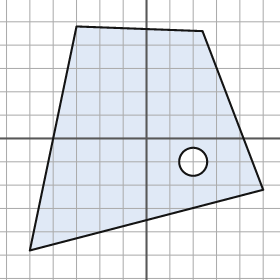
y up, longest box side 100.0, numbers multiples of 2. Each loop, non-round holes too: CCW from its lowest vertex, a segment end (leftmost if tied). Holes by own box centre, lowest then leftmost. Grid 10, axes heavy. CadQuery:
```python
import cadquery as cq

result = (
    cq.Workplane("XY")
    .moveTo(-50.0, -48.0)
    .lineTo(50.0, -22.0)
    .lineTo(24.0, 46.0)
    .lineTo(-30.0, 48.0)
    .close()
    .moveTo(20.0, -10.0)
    .circle(6.0)
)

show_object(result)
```